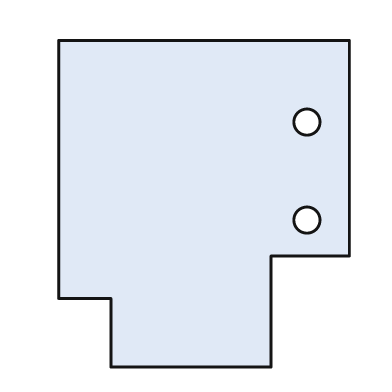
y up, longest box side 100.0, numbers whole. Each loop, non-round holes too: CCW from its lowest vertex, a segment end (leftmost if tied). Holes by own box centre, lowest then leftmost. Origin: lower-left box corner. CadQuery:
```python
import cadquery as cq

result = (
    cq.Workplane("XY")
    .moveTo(16.0, 0.0)
    .lineTo(65.0, 0.0)
    .lineTo(65.0, 34.0)
    .lineTo(89.0, 34.0)
    .lineTo(89.0, 100.0)
    .lineTo(0.0, 100.0)
    .lineTo(0.0, 21.0)
    .lineTo(16.0, 21.0)
    .close()
    .moveTo(76.0, 45.0)
    .circle(4.0)
    .moveTo(76.0, 75.0)
    .circle(4.0)
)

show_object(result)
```